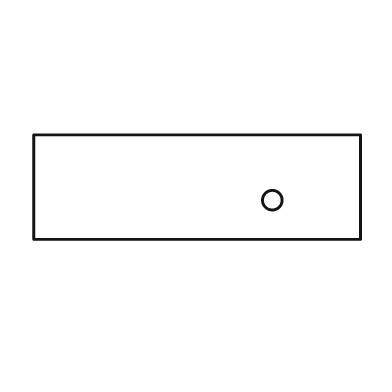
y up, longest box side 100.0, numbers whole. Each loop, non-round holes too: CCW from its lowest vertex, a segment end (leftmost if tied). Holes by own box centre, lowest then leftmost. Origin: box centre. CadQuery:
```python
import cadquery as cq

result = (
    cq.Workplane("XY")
    .moveTo(-50.0, -16.0)
    .lineTo(50.0, -16.0)
    .lineTo(50.0, 16.0)
    .lineTo(-50.0, 16.0)
    .close()
    .moveTo(23.0, -4.0)
    .circle(3.0)
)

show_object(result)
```